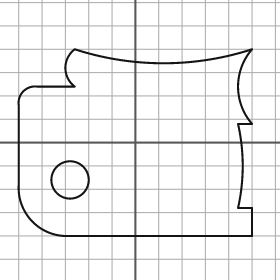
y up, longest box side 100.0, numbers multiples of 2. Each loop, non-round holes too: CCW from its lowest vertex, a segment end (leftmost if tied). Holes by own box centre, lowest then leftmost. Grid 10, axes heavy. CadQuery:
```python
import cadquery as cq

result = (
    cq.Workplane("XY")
    .moveTo(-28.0, -40.0)
    .lineTo(50.0, -40.0)
    .lineTo(50.0, -28.0)
    .lineTo(44.0, -28.0)
    .threePointArc((46.0, -10.0), (44.0, 8.0))
    .lineTo(50.0, 8.0)
    .threePointArc((44.0, 24.0), (50.0, 40.0))
    .threePointArc((12.0, 34.0), (-26.0, 40.0))
    .threePointArc((-30.0, 32.0), (-26.0, 24.0))
    .lineTo(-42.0, 24.0)
    .threePointArc((-48.0, 22.0), (-50.0, 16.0))
    .lineTo(-50.0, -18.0)
    .threePointArc((-44.0, -34.0), (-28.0, -40.0))
    .close()
    .moveTo(-28.0, -16.0)
    .circle(8.0)
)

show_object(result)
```